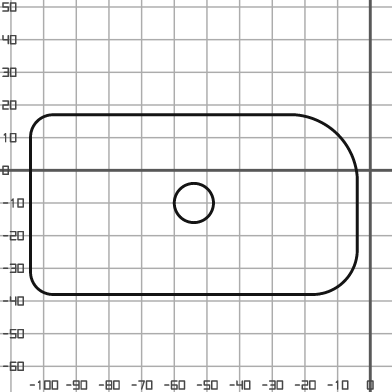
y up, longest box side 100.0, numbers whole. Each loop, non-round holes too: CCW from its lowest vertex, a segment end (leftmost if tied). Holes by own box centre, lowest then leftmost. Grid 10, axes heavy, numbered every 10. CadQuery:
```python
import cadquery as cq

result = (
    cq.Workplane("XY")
    .moveTo(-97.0, -38.0)
    .lineTo(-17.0, -38.0)
    .threePointArc((-8.0, -34.0), (-4.0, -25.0))
    .lineTo(-4.0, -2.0)
    .threePointArc((-10.0, 11.0), (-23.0, 17.0))
    .lineTo(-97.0, 17.0)
    .threePointArc((-102.0, 15.0), (-104.0, 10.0))
    .lineTo(-104.0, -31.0)
    .threePointArc((-102.0, -36.0), (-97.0, -38.0))
    .close()
    .moveTo(-54.0, -10.0)
    .circle(6.0)
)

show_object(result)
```